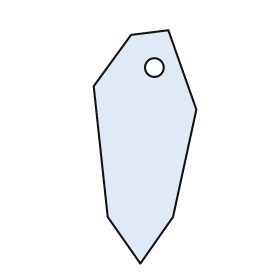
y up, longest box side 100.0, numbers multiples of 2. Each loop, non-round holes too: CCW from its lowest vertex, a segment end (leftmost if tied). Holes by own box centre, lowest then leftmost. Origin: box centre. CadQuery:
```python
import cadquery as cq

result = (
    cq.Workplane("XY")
    .moveTo(-2.0, -50.0)
    .lineTo(12.0, -30.0)
    .lineTo(22.0, 16.0)
    .lineTo(10.0, 50.0)
    .lineTo(-6.0, 48.0)
    .lineTo(-22.0, 26.0)
    .lineTo(-16.0, -30.0)
    .close()
    .moveTo(4.0, 34.0)
    .circle(4.0)
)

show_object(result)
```